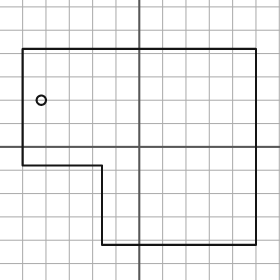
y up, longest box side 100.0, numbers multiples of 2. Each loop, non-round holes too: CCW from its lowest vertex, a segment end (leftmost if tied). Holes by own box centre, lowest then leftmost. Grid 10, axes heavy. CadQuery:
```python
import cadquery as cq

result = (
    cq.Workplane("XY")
    .moveTo(-16.0, -42.0)
    .lineTo(50.0, -42.0)
    .lineTo(50.0, 42.0)
    .lineTo(-50.0, 42.0)
    .lineTo(-50.0, -8.0)
    .lineTo(-16.0, -8.0)
    .close()
    .moveTo(-42.0, 20.0)
    .circle(2.0)
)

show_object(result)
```